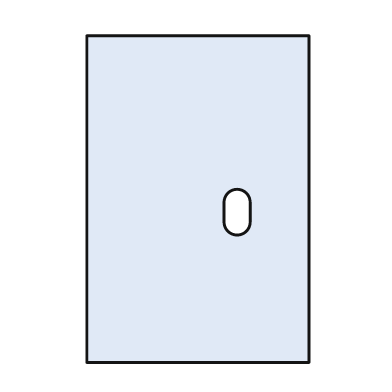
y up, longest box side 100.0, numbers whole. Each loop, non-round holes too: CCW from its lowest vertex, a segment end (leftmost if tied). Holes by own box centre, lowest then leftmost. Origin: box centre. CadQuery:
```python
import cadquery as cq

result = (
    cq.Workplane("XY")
    .moveTo(-34.0, -50.0)
    .lineTo(34.0, -50.0)
    .lineTo(34.0, 50.0)
    .lineTo(-34.0, 50.0)
    .close()
    .moveTo(8.0, -7.0)
    .threePointArc((12.0, -11.0), (16.0, -7.0))
    .lineTo(16.0, -1.0)
    .threePointArc((12.0, 3.0), (8.0, -1.0))
    .close()
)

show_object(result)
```